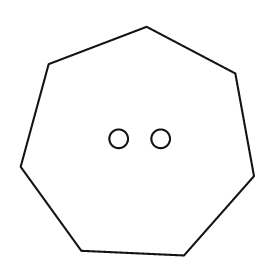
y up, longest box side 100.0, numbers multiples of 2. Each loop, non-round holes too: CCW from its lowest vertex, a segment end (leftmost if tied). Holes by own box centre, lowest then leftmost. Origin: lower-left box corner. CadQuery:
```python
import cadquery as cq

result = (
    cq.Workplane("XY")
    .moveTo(70.0, 0.0)
    .lineTo(100.0, 34.0)
    .lineTo(92.0, 78.0)
    .lineTo(54.0, 98.0)
    .lineTo(12.0, 82.0)
    .lineTo(0.0, 38.0)
    .lineTo(26.0, 2.0)
    .close()
    .moveTo(42.0, 50.0)
    .circle(4.0)
    .moveTo(60.0, 50.0)
    .circle(4.0)
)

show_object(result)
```